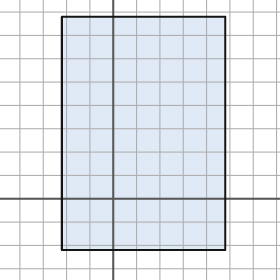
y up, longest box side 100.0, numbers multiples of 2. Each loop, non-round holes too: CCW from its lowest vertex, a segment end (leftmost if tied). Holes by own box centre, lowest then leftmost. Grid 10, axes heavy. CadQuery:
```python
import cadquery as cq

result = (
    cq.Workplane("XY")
    .moveTo(-22.0, -22.0)
    .lineTo(48.0, -22.0)
    .lineTo(48.0, 78.0)
    .lineTo(-22.0, 78.0)
    .close()
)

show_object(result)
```